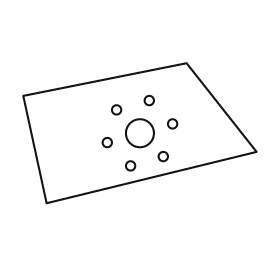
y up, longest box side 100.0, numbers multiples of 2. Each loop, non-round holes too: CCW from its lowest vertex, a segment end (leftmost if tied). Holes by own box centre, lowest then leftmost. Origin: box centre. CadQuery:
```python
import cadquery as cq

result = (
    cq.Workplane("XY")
    .moveTo(-40.0, -30.0)
    .lineTo(50.0, -8.0)
    .lineTo(20.0, 30.0)
    .lineTo(-50.0, 16.0)
    .close()
    .moveTo(-4.0, -14.0)
    .circle(2.0)
    .moveTo(10.0, -10.0)
    .circle(2.0)
    .moveTo(-14.0, -4.0)
    .circle(2.0)
    .moveTo(0.0, 0.0)
    .circle(6.0)
    .moveTo(14.0, 4.0)
    .circle(2.0)
    .moveTo(-10.0, 10.0)
    .circle(2.0)
    .moveTo(4.0, 14.0)
    .circle(2.0)
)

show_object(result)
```